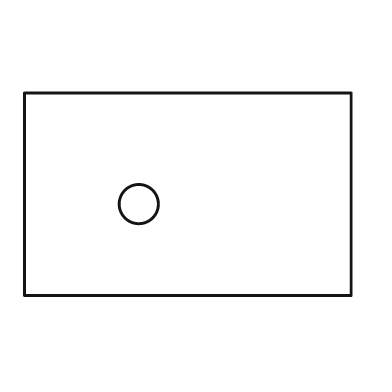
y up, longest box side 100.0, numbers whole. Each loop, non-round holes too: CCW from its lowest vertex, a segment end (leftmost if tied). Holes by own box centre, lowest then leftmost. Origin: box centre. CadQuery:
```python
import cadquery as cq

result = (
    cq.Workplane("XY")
    .moveTo(-50.0, -31.0)
    .lineTo(50.0, -31.0)
    .lineTo(50.0, 31.0)
    .lineTo(-50.0, 31.0)
    .close()
    .moveTo(-15.0, -3.0)
    .circle(6.0)
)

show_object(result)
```